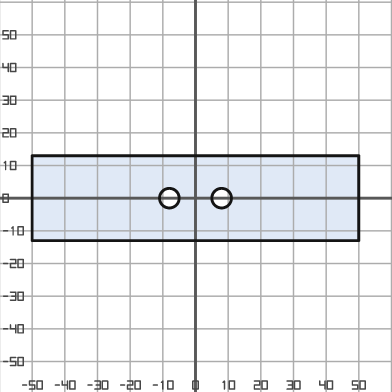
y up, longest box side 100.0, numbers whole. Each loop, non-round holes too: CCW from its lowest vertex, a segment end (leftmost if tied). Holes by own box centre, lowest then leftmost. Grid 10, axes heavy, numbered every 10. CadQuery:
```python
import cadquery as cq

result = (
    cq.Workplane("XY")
    .moveTo(-50.0, -13.0)
    .lineTo(50.0, -13.0)
    .lineTo(50.0, 13.0)
    .lineTo(-50.0, 13.0)
    .close()
    .moveTo(-8.0, 0.0)
    .circle(3.0)
    .moveTo(8.0, 0.0)
    .circle(3.0)
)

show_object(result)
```